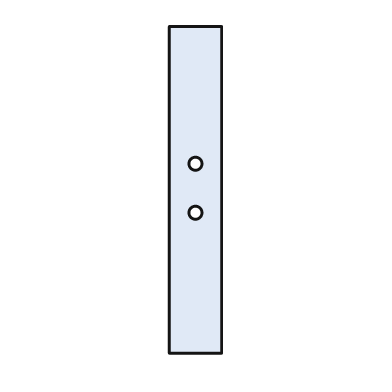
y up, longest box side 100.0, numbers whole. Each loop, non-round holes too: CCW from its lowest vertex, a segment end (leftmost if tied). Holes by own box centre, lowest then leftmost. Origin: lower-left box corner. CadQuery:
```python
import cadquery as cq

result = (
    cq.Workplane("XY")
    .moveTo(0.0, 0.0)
    .lineTo(16.0, 0.0)
    .lineTo(16.0, 100.0)
    .lineTo(0.0, 100.0)
    .close()
    .moveTo(8.0, 43.0)
    .circle(2.0)
    .moveTo(8.0, 58.0)
    .circle(2.0)
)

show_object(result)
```